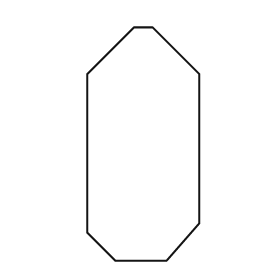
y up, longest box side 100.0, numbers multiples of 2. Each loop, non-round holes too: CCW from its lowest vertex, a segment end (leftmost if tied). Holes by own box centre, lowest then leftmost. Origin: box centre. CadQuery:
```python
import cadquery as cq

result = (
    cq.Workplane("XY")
    .moveTo(-12.0, -50.0)
    .lineTo(10.0, -50.0)
    .lineTo(24.0, -34.0)
    .lineTo(24.0, 30.0)
    .lineTo(4.0, 50.0)
    .lineTo(-4.0, 50.0)
    .lineTo(-24.0, 30.0)
    .lineTo(-24.0, -38.0)
    .close()
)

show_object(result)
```